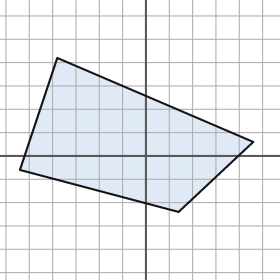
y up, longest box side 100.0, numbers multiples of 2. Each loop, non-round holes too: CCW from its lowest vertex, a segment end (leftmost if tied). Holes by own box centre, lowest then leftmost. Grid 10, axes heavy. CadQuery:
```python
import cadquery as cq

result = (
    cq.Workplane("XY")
    .moveTo(14.0, -24.0)
    .lineTo(46.0, 6.0)
    .lineTo(-38.0, 42.0)
    .lineTo(-54.0, -6.0)
    .close()
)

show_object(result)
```